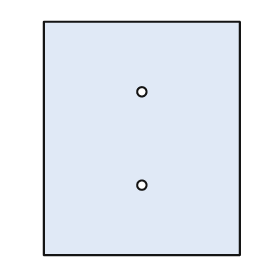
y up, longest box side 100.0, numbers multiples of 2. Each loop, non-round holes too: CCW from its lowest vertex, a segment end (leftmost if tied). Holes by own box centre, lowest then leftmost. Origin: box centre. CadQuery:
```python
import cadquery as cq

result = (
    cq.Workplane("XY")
    .moveTo(-42.0, -50.0)
    .lineTo(42.0, -50.0)
    .lineTo(42.0, 50.0)
    .lineTo(-42.0, 50.0)
    .close()
    .moveTo(0.0, -20.0)
    .circle(2.0)
    .moveTo(0.0, 20.0)
    .circle(2.0)
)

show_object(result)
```